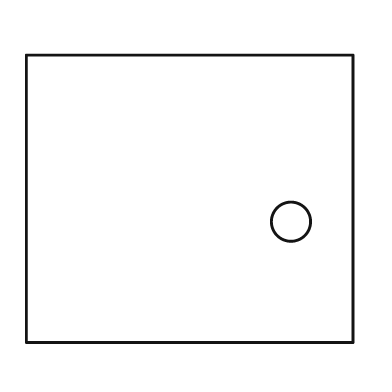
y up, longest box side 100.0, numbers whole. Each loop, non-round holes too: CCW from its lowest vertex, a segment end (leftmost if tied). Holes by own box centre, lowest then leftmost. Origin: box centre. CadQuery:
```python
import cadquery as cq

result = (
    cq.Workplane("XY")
    .moveTo(-50.0, -44.0)
    .lineTo(50.0, -44.0)
    .lineTo(50.0, 44.0)
    .lineTo(-50.0, 44.0)
    .close()
    .moveTo(31.0, -7.0)
    .circle(6.0)
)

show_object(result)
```